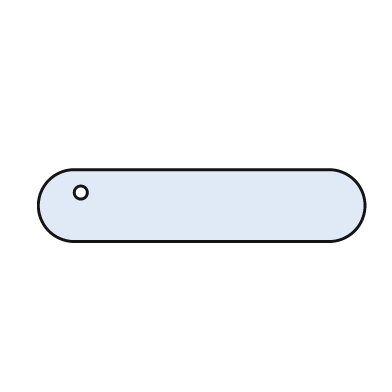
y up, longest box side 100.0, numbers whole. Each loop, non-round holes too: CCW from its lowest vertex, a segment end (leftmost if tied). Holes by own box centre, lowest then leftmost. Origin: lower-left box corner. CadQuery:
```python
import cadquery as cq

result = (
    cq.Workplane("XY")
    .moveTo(11.0, 0.0)
    .lineTo(89.0, 0.0)
    .threePointArc((100.0, 11.0), (89.0, 22.0))
    .lineTo(11.0, 22.0)
    .threePointArc((0.0, 11.0), (11.0, 0.0))
    .close()
    .moveTo(13.0, 15.0)
    .circle(2.0)
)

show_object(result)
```